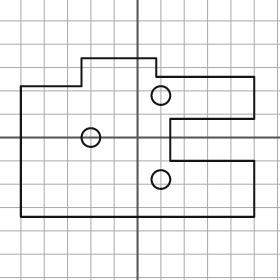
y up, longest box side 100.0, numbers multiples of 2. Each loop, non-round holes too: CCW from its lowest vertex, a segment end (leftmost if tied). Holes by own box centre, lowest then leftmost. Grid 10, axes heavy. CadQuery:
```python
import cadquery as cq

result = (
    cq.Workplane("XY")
    .moveTo(-50.0, -34.0)
    .lineTo(50.0, -34.0)
    .lineTo(50.0, -10.0)
    .lineTo(14.0, -10.0)
    .lineTo(14.0, 8.0)
    .lineTo(50.0, 8.0)
    .lineTo(50.0, 26.0)
    .lineTo(8.0, 26.0)
    .lineTo(8.0, 34.0)
    .lineTo(-24.0, 34.0)
    .lineTo(-24.0, 22.0)
    .lineTo(-50.0, 22.0)
    .close()
    .moveTo(10.0, -18.0)
    .circle(4.0)
    .moveTo(-20.0, 0.0)
    .circle(4.0)
    .moveTo(10.0, 18.0)
    .circle(4.0)
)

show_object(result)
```